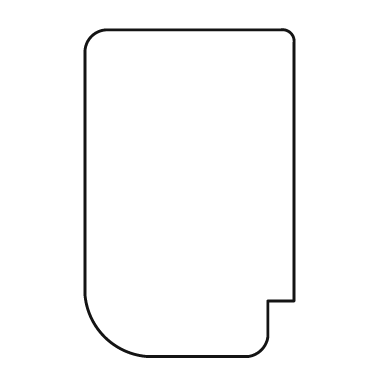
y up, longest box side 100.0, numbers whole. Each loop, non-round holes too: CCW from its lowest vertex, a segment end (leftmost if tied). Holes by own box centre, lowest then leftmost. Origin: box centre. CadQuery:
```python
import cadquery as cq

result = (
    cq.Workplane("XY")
    .moveTo(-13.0, -50.0)
    .lineTo(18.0, -50.0)
    .threePointArc((22.0, -48.0), (24.0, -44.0))
    .lineTo(24.0, -33.0)
    .lineTo(32.0, -33.0)
    .lineTo(32.0, 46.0)
    .threePointArc((31.0, 49.0), (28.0, 50.0))
    .lineTo(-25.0, 50.0)
    .threePointArc((-30.0, 48.0), (-32.0, 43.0))
    .lineTo(-32.0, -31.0)
    .threePointArc((-26.0, -44.0), (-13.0, -50.0))
    .close()
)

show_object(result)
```